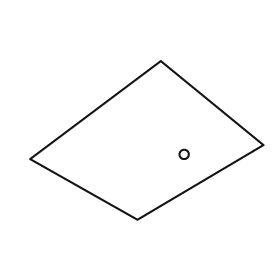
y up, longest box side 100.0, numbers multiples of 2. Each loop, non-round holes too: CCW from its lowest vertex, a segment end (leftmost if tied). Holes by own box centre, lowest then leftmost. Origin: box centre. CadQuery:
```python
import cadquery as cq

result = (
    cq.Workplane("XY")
    .moveTo(-4.0, -34.0)
    .lineTo(50.0, -2.0)
    .lineTo(6.0, 34.0)
    .lineTo(-50.0, -8.0)
    .close()
    .moveTo(16.0, -6.0)
    .circle(2.0)
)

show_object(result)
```